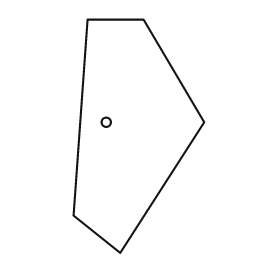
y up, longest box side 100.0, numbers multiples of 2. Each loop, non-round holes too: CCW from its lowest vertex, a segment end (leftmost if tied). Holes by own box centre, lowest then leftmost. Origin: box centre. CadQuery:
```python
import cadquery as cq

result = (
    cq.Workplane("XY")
    .moveTo(-8.0, -50.0)
    .lineTo(28.0, 6.0)
    .lineTo(2.0, 50.0)
    .lineTo(-22.0, 50.0)
    .lineTo(-28.0, -34.0)
    .close()
    .moveTo(-14.0, 6.0)
    .circle(2.0)
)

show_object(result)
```